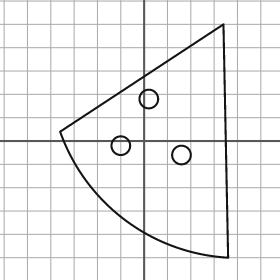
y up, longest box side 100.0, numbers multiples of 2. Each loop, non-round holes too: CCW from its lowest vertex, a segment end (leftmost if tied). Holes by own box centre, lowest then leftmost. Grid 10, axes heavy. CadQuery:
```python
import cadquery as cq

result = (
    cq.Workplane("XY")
    .moveTo(36.0, -50.0)
    .lineTo(34.0, 50.0)
    .lineTo(-36.0, 4.0)
    .threePointArc((-8.0, -34.0), (36.0, -50.0))
    .close()
    .moveTo(16.0, -6.0)
    .circle(4.0)
    .moveTo(-10.0, -2.0)
    .circle(4.0)
    .moveTo(2.0, 18.0)
    .circle(4.0)
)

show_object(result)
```